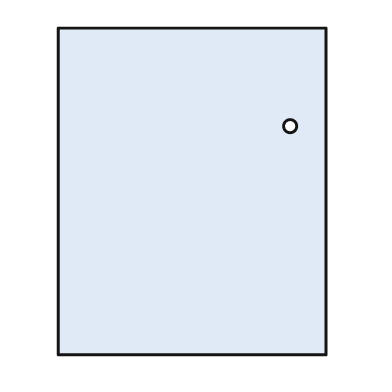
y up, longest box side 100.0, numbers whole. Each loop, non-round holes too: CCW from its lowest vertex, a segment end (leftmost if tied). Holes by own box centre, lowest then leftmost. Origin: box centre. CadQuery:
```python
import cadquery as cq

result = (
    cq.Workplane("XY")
    .moveTo(-41.0, -50.0)
    .lineTo(41.0, -50.0)
    .lineTo(41.0, 50.0)
    .lineTo(-41.0, 50.0)
    .close()
    .moveTo(30.0, 20.0)
    .circle(2.0)
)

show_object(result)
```